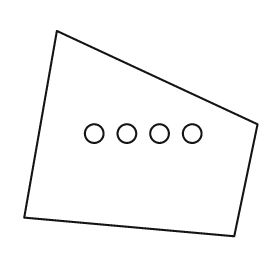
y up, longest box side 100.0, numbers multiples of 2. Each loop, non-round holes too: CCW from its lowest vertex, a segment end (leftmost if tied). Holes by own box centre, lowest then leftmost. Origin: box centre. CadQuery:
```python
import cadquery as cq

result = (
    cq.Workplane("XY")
    .moveTo(40.0, -44.0)
    .lineTo(50.0, 4.0)
    .lineTo(-36.0, 44.0)
    .lineTo(-50.0, -36.0)
    .close()
    .moveTo(-20.0, 0.0)
    .circle(4.0)
    .moveTo(-6.0, 0.0)
    .circle(4.0)
    .moveTo(8.0, 0.0)
    .circle(4.0)
    .moveTo(22.0, 0.0)
    .circle(4.0)
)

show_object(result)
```